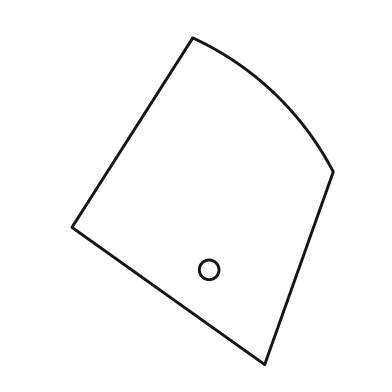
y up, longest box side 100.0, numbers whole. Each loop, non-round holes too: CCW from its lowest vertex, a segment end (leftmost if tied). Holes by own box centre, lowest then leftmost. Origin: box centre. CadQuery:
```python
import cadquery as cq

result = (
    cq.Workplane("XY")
    .moveTo(19.0, -50.0)
    .lineTo(40.0, 9.0)
    .threePointArc((22.0, 33.0), (-3.0, 50.0))
    .lineTo(-40.0, -8.0)
    .close()
    .moveTo(2.0, -21.0)
    .circle(3.0)
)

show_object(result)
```